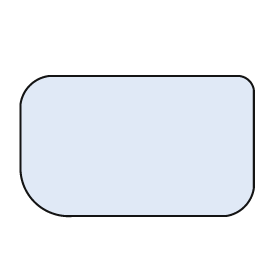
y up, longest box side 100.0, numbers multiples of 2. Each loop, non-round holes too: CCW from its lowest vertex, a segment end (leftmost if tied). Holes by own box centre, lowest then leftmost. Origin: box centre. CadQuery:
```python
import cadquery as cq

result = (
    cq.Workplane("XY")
    .moveTo(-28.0, -30.0)
    .lineTo(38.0, -30.0)
    .threePointArc((46.0, -26.0), (50.0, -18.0))
    .lineTo(50.0, 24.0)
    .threePointArc((48.0, 28.0), (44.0, 30.0))
    .lineTo(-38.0, 30.0)
    .threePointArc((-46.0, 26.0), (-50.0, 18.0))
    .lineTo(-50.0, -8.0)
    .threePointArc((-44.0, -24.0), (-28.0, -30.0))
    .close()
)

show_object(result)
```